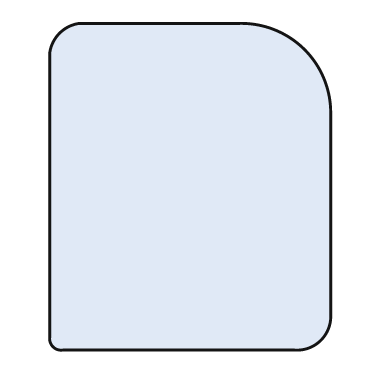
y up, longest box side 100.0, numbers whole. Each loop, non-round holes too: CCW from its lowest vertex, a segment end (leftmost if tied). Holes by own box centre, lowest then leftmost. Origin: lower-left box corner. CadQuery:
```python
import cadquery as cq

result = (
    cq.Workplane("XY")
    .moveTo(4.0, 0.0)
    .lineTo(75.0, 0.0)
    .threePointArc((83.0, 3.0), (86.0, 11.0))
    .lineTo(86.0, 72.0)
    .threePointArc((78.0, 92.0), (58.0, 100.0))
    .lineTo(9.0, 100.0)
    .threePointArc((3.0, 97.0), (0.0, 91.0))
    .lineTo(0.0, 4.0)
    .threePointArc((1.0, 1.0), (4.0, 0.0))
    .close()
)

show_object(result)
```